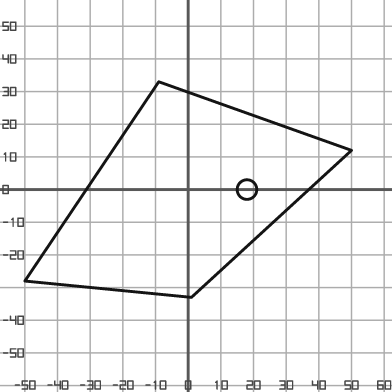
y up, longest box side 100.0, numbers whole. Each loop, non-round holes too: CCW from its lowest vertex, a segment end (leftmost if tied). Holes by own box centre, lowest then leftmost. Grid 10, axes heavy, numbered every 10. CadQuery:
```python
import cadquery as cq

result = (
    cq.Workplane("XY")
    .moveTo(1.0, -33.0)
    .lineTo(50.0, 12.0)
    .lineTo(-9.0, 33.0)
    .lineTo(-50.0, -28.0)
    .close()
    .moveTo(18.0, 0.0)
    .circle(3.0)
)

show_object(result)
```